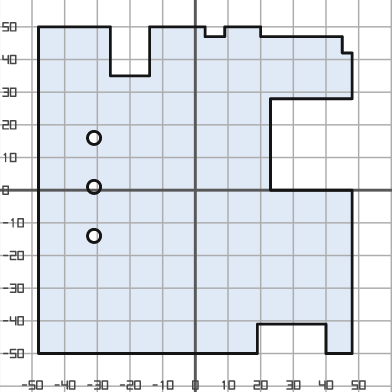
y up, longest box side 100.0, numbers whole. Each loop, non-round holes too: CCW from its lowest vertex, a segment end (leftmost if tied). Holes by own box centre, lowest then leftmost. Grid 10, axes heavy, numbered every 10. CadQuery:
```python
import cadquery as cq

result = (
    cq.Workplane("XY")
    .moveTo(-48.0, -50.0)
    .lineTo(19.0, -50.0)
    .lineTo(19.0, -41.0)
    .lineTo(40.0, -41.0)
    .lineTo(40.0, -50.0)
    .lineTo(48.0, -50.0)
    .lineTo(48.0, 0.0)
    .lineTo(23.0, 0.0)
    .lineTo(23.0, 28.0)
    .lineTo(48.0, 28.0)
    .lineTo(48.0, 42.0)
    .lineTo(45.0, 42.0)
    .lineTo(45.0, 47.0)
    .lineTo(20.0, 47.0)
    .lineTo(20.0, 50.0)
    .lineTo(9.0, 50.0)
    .lineTo(9.0, 47.0)
    .lineTo(3.0, 47.0)
    .lineTo(3.0, 50.0)
    .lineTo(-14.0, 50.0)
    .lineTo(-14.0, 35.0)
    .lineTo(-26.0, 35.0)
    .lineTo(-26.0, 50.0)
    .lineTo(-48.0, 50.0)
    .close()
    .moveTo(-31.0, -14.0)
    .circle(2.0)
    .moveTo(-31.0, 1.0)
    .circle(2.0)
    .moveTo(-31.0, 16.0)
    .circle(2.0)
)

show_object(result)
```